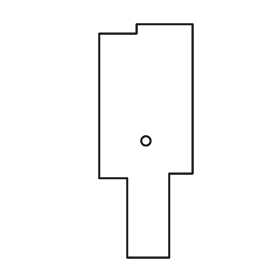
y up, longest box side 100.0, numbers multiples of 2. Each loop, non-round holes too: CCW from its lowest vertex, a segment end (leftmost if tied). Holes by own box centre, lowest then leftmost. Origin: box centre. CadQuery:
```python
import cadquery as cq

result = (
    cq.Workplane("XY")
    .moveTo(-8.0, -50.0)
    .lineTo(10.0, -50.0)
    .lineTo(10.0, -14.0)
    .lineTo(20.0, -14.0)
    .lineTo(20.0, 50.0)
    .lineTo(-4.0, 50.0)
    .lineTo(-4.0, 46.0)
    .lineTo(-20.0, 46.0)
    .lineTo(-20.0, -16.0)
    .lineTo(-8.0, -16.0)
    .close()
    .moveTo(0.0, 0.0)
    .circle(2.0)
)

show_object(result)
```